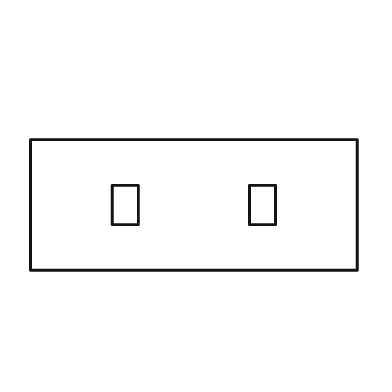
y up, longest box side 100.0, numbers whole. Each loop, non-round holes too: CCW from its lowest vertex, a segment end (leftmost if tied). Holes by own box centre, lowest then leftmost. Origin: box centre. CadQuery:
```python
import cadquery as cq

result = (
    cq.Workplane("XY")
    .moveTo(-50.0, -20.0)
    .lineTo(50.0, -20.0)
    .lineTo(50.0, 20.0)
    .lineTo(-50.0, 20.0)
    .close()
    .moveTo(-25.0, -6.0)
    .lineTo(-17.0, -6.0)
    .lineTo(-17.0, 6.0)
    .lineTo(-25.0, 6.0)
    .close()
    .moveTo(17.0, -6.0)
    .lineTo(25.0, -6.0)
    .lineTo(25.0, 6.0)
    .lineTo(17.0, 6.0)
    .close()
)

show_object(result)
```